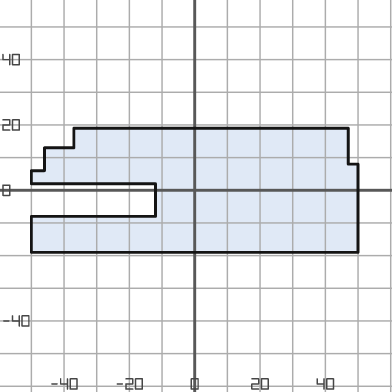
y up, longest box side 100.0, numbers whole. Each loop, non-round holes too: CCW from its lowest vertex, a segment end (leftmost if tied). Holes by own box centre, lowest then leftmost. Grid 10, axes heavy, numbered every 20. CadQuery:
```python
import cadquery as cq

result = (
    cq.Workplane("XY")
    .moveTo(-50.0, -19.0)
    .lineTo(50.0, -19.0)
    .lineTo(50.0, 8.0)
    .lineTo(47.0, 8.0)
    .lineTo(47.0, 19.0)
    .lineTo(-37.0, 19.0)
    .lineTo(-37.0, 13.0)
    .lineTo(-46.0, 13.0)
    .lineTo(-46.0, 6.0)
    .lineTo(-50.0, 6.0)
    .lineTo(-50.0, 2.0)
    .lineTo(-12.0, 2.0)
    .lineTo(-12.0, -8.0)
    .lineTo(-50.0, -8.0)
    .close()
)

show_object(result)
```